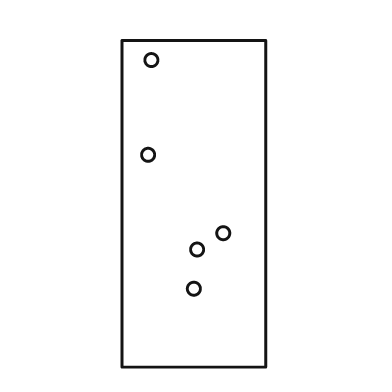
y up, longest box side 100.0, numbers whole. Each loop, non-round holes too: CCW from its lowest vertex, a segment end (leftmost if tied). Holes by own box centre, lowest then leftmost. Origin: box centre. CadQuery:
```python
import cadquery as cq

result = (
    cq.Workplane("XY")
    .moveTo(-22.0, -50.0)
    .lineTo(22.0, -50.0)
    .lineTo(22.0, 50.0)
    .lineTo(-22.0, 50.0)
    .close()
    .moveTo(0.0, -26.0)
    .circle(2.0)
    .moveTo(1.0, -14.0)
    .circle(2.0)
    .moveTo(9.0, -9.0)
    .circle(2.0)
    .moveTo(-14.0, 15.0)
    .circle(2.0)
    .moveTo(-13.0, 44.0)
    .circle(2.0)
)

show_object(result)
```